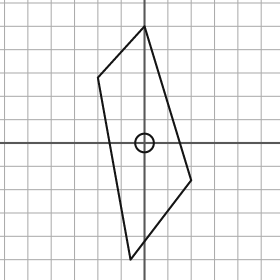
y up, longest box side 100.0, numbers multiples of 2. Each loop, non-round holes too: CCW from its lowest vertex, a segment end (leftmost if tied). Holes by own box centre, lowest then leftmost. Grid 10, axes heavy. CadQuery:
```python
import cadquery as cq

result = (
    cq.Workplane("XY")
    .moveTo(-6.0, -50.0)
    .lineTo(20.0, -16.0)
    .lineTo(0.0, 50.0)
    .lineTo(-20.0, 28.0)
    .close()
    .moveTo(0.0, 0.0)
    .circle(4.0)
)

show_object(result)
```